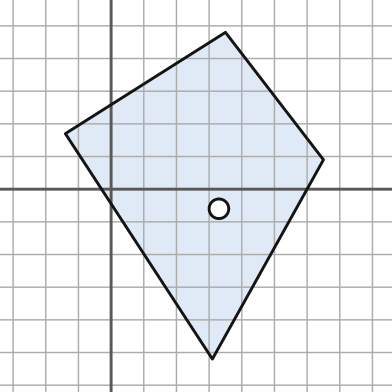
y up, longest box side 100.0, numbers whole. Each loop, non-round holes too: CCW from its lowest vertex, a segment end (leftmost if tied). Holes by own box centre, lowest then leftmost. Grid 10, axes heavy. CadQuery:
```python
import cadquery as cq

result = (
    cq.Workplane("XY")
    .moveTo(31.0, -52.0)
    .lineTo(65.0, 9.0)
    .lineTo(35.0, 48.0)
    .lineTo(-14.0, 17.0)
    .close()
    .moveTo(33.0, -6.0)
    .circle(3.0)
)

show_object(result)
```